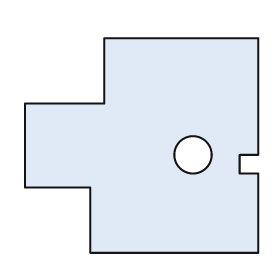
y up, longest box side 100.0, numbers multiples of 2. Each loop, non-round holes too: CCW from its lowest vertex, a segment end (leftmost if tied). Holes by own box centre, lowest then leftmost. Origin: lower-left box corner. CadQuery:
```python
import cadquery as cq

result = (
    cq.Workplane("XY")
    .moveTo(28.0, 0.0)
    .lineTo(100.0, 0.0)
    .lineTo(100.0, 34.0)
    .lineTo(92.0, 34.0)
    .lineTo(92.0, 42.0)
    .lineTo(100.0, 42.0)
    .lineTo(100.0, 92.0)
    .lineTo(34.0, 92.0)
    .lineTo(34.0, 64.0)
    .lineTo(0.0, 64.0)
    .lineTo(0.0, 28.0)
    .lineTo(28.0, 28.0)
    .close()
    .moveTo(72.0, 42.0)
    .circle(8.0)
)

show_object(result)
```